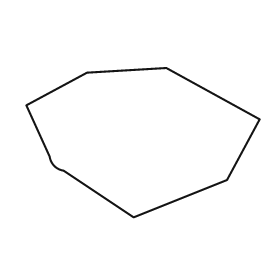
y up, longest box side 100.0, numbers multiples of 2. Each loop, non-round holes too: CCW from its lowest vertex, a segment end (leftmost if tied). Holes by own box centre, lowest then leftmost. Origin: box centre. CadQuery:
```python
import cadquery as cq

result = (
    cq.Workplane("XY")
    .moveTo(-4.0, -32.0)
    .lineTo(36.0, -16.0)
    .lineTo(50.0, 10.0)
    .lineTo(10.0, 32.0)
    .lineTo(-24.0, 30.0)
    .lineTo(-50.0, 16.0)
    .lineTo(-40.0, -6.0)
    .threePointArc((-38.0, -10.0), (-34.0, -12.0))
    .close()
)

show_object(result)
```